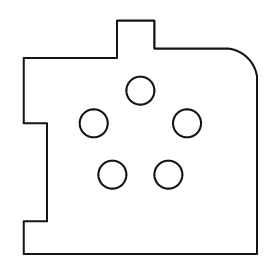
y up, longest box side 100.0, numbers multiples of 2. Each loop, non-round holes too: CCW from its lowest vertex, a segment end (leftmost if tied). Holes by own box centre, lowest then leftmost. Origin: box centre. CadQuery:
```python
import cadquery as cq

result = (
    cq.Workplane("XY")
    .moveTo(-50.0, -50.0)
    .lineTo(50.0, -50.0)
    .lineTo(50.0, 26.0)
    .threePointArc((46.0, 34.0), (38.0, 38.0))
    .lineTo(6.0, 38.0)
    .lineTo(6.0, 50.0)
    .lineTo(-10.0, 50.0)
    .lineTo(-10.0, 34.0)
    .lineTo(-50.0, 34.0)
    .lineTo(-50.0, 6.0)
    .lineTo(-40.0, 6.0)
    .lineTo(-40.0, -36.0)
    .lineTo(-50.0, -36.0)
    .close()
    .moveTo(-12.0, -16.0)
    .circle(6.0)
    .moveTo(12.0, -16.0)
    .circle(6.0)
    .moveTo(-20.0, 6.0)
    .circle(6.0)
    .moveTo(20.0, 6.0)
    .circle(6.0)
    .moveTo(0.0, 20.0)
    .circle(6.0)
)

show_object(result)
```